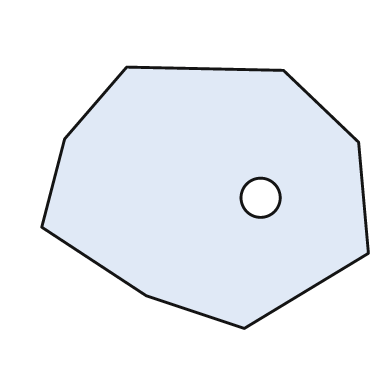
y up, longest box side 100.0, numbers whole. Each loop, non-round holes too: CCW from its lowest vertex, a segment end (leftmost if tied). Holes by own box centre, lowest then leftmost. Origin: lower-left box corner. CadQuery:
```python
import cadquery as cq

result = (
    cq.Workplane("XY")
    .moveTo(62.0, 0.0)
    .lineTo(100.0, 23.0)
    .lineTo(97.0, 57.0)
    .lineTo(74.0, 79.0)
    .lineTo(26.0, 80.0)
    .lineTo(7.0, 58.0)
    .lineTo(0.0, 31.0)
    .lineTo(32.0, 10.0)
    .close()
    .moveTo(67.0, 40.0)
    .circle(6.0)
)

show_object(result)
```